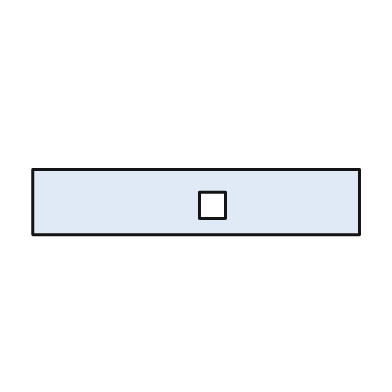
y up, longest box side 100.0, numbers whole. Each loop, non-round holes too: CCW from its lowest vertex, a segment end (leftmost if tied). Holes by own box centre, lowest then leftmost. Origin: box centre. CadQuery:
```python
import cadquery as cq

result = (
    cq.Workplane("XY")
    .moveTo(-50.0, -10.0)
    .lineTo(50.0, -10.0)
    .lineTo(50.0, 10.0)
    .lineTo(-50.0, 10.0)
    .close()
    .moveTo(1.0, -5.0)
    .lineTo(9.0, -5.0)
    .lineTo(9.0, 3.0)
    .lineTo(1.0, 3.0)
    .close()
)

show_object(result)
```